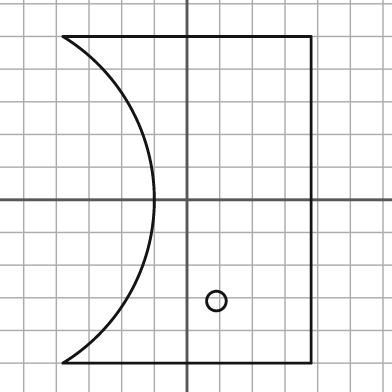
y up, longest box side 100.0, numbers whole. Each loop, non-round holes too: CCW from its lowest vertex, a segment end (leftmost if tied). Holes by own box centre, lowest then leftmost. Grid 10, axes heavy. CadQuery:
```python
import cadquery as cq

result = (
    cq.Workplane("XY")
    .moveTo(-38.0, -50.0)
    .lineTo(38.0, -50.0)
    .lineTo(38.0, 50.0)
    .lineTo(-38.0, 50.0)
    .threePointArc((-10.0, 0.0), (-38.0, -50.0))
    .close()
    .moveTo(9.0, -31.0)
    .circle(3.0)
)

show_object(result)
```